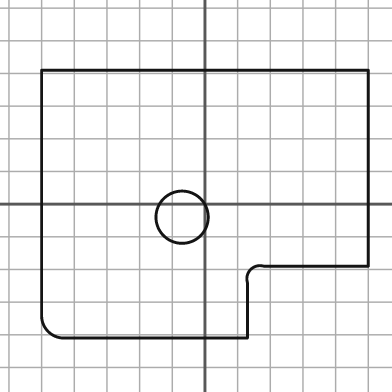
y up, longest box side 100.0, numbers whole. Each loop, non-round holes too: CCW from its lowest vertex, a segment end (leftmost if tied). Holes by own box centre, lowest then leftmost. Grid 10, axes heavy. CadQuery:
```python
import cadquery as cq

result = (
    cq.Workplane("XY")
    .moveTo(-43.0, -41.0)
    .lineTo(13.0, -41.0)
    .lineTo(13.0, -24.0)
    .threePointArc((14.0, -20.0), (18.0, -19.0))
    .lineTo(50.0, -19.0)
    .lineTo(50.0, 41.0)
    .lineTo(-50.0, 41.0)
    .lineTo(-50.0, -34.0)
    .threePointArc((-48.0, -39.0), (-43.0, -41.0))
    .close()
    .moveTo(-7.0, -4.0)
    .circle(8.0)
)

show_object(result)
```